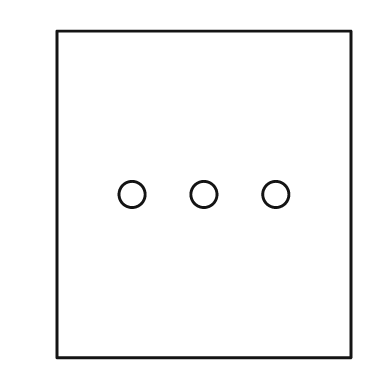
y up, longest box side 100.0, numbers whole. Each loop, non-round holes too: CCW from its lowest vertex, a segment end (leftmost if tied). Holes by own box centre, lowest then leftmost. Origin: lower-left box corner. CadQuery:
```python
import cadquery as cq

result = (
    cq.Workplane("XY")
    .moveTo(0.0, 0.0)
    .lineTo(90.0, 0.0)
    .lineTo(90.0, 100.0)
    .lineTo(0.0, 100.0)
    .close()
    .moveTo(23.0, 50.0)
    .circle(4.0)
    .moveTo(45.0, 50.0)
    .circle(4.0)
    .moveTo(67.0, 50.0)
    .circle(4.0)
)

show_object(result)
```